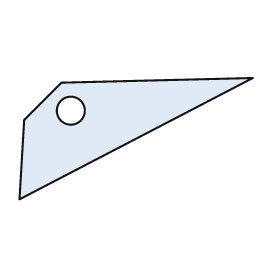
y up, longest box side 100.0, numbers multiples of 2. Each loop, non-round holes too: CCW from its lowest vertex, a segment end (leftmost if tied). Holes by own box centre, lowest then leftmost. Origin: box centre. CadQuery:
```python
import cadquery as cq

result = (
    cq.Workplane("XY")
    .moveTo(-50.0, -26.0)
    .lineTo(50.0, 26.0)
    .lineTo(-32.0, 24.0)
    .lineTo(-48.0, 8.0)
    .close()
    .moveTo(-28.0, 12.0)
    .circle(6.0)
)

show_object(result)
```